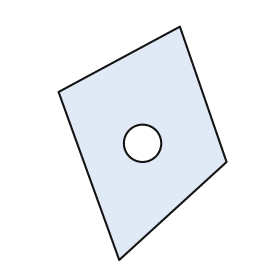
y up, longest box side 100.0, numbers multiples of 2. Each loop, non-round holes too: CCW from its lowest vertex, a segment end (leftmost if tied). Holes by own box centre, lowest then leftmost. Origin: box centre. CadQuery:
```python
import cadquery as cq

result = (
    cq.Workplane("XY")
    .moveTo(-10.0, -50.0)
    .lineTo(36.0, -8.0)
    .lineTo(16.0, 50.0)
    .lineTo(-36.0, 22.0)
    .close()
    .moveTo(0.0, 0.0)
    .circle(8.0)
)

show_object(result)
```